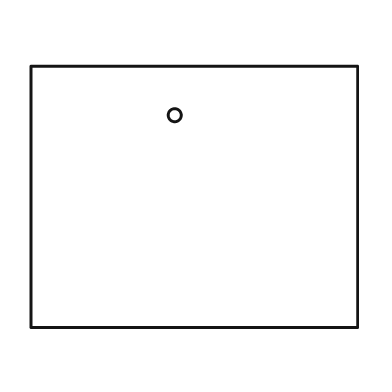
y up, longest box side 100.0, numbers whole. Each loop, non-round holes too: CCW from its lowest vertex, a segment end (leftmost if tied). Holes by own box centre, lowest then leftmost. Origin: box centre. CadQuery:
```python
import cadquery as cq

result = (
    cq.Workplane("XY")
    .moveTo(-50.0, -40.0)
    .lineTo(50.0, -40.0)
    .lineTo(50.0, 40.0)
    .lineTo(-50.0, 40.0)
    .close()
    .moveTo(-6.0, 25.0)
    .circle(2.0)
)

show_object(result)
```